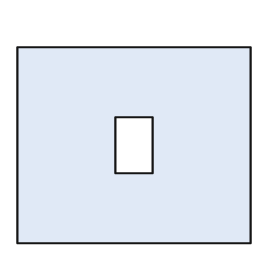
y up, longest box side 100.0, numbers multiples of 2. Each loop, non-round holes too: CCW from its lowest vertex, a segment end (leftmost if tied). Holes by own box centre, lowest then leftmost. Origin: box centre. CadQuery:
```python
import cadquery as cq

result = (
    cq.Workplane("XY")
    .moveTo(-50.0, -42.0)
    .lineTo(50.0, -42.0)
    .lineTo(50.0, 42.0)
    .lineTo(-50.0, 42.0)
    .close()
    .moveTo(-8.0, -12.0)
    .lineTo(8.0, -12.0)
    .lineTo(8.0, 12.0)
    .lineTo(-8.0, 12.0)
    .close()
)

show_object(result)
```